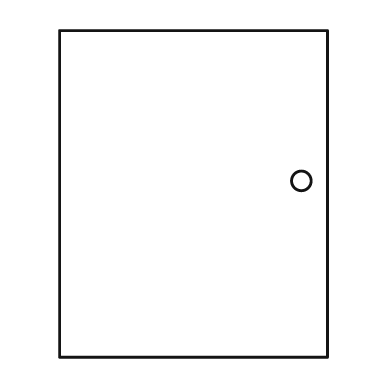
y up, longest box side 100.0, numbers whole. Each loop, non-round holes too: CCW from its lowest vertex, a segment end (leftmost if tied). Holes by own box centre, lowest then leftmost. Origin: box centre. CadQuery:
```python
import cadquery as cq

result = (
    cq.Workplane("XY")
    .moveTo(-41.0, -50.0)
    .lineTo(41.0, -50.0)
    .lineTo(41.0, 50.0)
    .lineTo(-41.0, 50.0)
    .close()
    .moveTo(33.0, 4.0)
    .circle(3.0)
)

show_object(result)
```